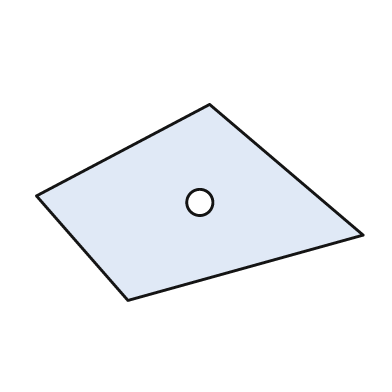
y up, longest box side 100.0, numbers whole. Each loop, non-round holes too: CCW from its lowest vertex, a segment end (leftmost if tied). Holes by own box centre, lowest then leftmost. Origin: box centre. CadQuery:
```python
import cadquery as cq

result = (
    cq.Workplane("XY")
    .moveTo(-22.0, -30.0)
    .lineTo(50.0, -10.0)
    .lineTo(3.0, 30.0)
    .lineTo(-50.0, 2.0)
    .close()
    .moveTo(0.0, 0.0)
    .circle(4.0)
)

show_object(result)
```